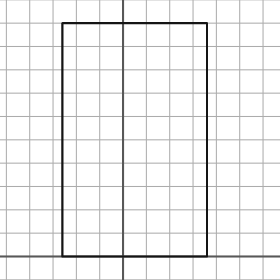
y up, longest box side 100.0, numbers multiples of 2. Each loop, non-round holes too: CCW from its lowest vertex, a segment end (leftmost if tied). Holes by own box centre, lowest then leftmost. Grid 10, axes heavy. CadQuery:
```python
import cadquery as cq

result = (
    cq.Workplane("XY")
    .moveTo(-26.0, 0.0)
    .lineTo(36.0, 0.0)
    .lineTo(36.0, 100.0)
    .lineTo(-26.0, 100.0)
    .close()
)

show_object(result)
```